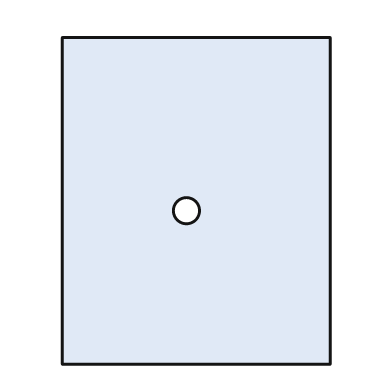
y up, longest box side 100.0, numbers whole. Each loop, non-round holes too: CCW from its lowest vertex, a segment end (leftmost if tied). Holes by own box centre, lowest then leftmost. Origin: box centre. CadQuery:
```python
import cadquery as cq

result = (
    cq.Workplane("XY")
    .moveTo(-41.0, -50.0)
    .lineTo(41.0, -50.0)
    .lineTo(41.0, 50.0)
    .lineTo(-41.0, 50.0)
    .close()
    .moveTo(-3.0, -3.0)
    .circle(4.0)
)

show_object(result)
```